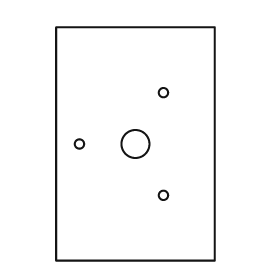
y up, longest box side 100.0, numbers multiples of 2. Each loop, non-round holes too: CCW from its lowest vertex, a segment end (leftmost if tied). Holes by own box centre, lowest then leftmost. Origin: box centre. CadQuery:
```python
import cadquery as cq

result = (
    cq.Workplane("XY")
    .moveTo(-34.0, -50.0)
    .lineTo(34.0, -50.0)
    .lineTo(34.0, 50.0)
    .lineTo(-34.0, 50.0)
    .close()
    .moveTo(12.0, -22.0)
    .circle(2.0)
    .moveTo(-24.0, 0.0)
    .circle(2.0)
    .moveTo(0.0, 0.0)
    .circle(6.0)
    .moveTo(12.0, 22.0)
    .circle(2.0)
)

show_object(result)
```